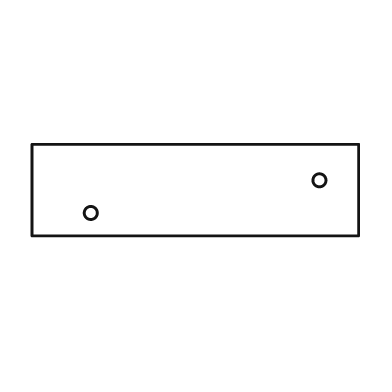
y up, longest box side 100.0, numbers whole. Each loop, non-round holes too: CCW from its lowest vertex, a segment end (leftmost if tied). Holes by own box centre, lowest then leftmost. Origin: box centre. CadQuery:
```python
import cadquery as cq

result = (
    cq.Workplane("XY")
    .moveTo(-50.0, -14.0)
    .lineTo(50.0, -14.0)
    .lineTo(50.0, 14.0)
    .lineTo(-50.0, 14.0)
    .close()
    .moveTo(-32.0, -7.0)
    .circle(2.0)
    .moveTo(38.0, 3.0)
    .circle(2.0)
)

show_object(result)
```